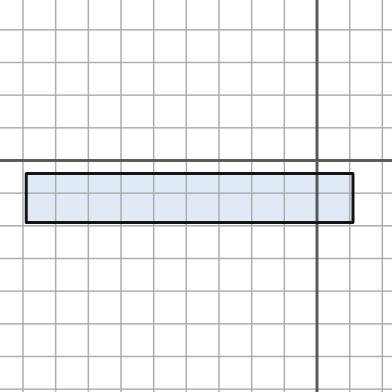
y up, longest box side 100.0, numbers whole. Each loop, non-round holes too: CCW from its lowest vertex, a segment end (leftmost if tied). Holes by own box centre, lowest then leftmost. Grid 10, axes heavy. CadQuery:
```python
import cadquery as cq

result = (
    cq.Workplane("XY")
    .moveTo(-89.0, -19.0)
    .lineTo(11.0, -19.0)
    .lineTo(11.0, -4.0)
    .lineTo(-89.0, -4.0)
    .close()
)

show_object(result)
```